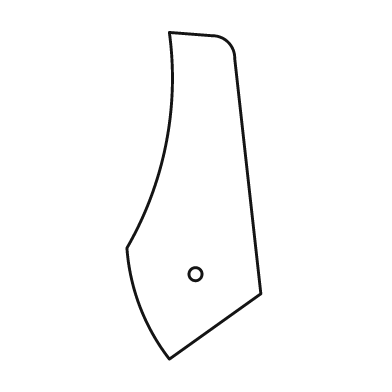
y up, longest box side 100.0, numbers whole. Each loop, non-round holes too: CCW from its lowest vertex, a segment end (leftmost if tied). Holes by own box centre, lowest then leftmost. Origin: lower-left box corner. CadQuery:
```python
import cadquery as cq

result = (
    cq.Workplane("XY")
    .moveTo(13.0, 0.0)
    .lineTo(41.0, 20.0)
    .lineTo(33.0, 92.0)
    .threePointArc((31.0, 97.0), (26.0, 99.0))
    .lineTo(13.0, 100.0)
    .threePointArc((12.0, 66.0), (0.0, 34.0))
    .threePointArc((4.0, 16.0), (13.0, 0.0))
    .close()
    .moveTo(21.0, 26.0)
    .circle(2.0)
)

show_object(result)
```